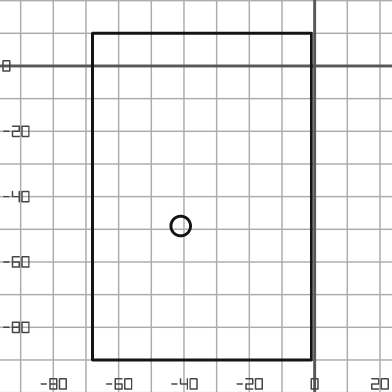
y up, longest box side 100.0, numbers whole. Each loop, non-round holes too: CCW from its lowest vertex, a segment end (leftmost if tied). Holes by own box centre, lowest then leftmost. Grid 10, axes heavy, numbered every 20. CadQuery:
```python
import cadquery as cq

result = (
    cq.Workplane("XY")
    .moveTo(-68.0, -90.0)
    .lineTo(-1.0, -90.0)
    .lineTo(-1.0, 10.0)
    .lineTo(-68.0, 10.0)
    .close()
    .moveTo(-41.0, -49.0)
    .circle(3.0)
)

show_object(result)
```